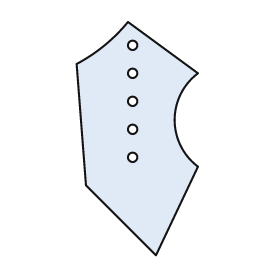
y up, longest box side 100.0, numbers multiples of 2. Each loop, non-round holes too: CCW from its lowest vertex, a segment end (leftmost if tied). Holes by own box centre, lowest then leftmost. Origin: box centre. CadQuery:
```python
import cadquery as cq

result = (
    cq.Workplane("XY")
    .moveTo(8.0, -50.0)
    .lineTo(26.0, -12.0)
    .threePointArc((16.0, 8.0), (26.0, 28.0))
    .lineTo(-4.0, 50.0)
    .threePointArc((-14.0, 40.0), (-26.0, 32.0))
    .lineTo(-22.0, -20.0)
    .close()
    .moveTo(-2.0, -8.0)
    .circle(2.0)
    .moveTo(-2.0, 4.0)
    .circle(2.0)
    .moveTo(-2.0, 16.0)
    .circle(2.0)
    .moveTo(-2.0, 28.0)
    .circle(2.0)
    .moveTo(-2.0, 40.0)
    .circle(2.0)
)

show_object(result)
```